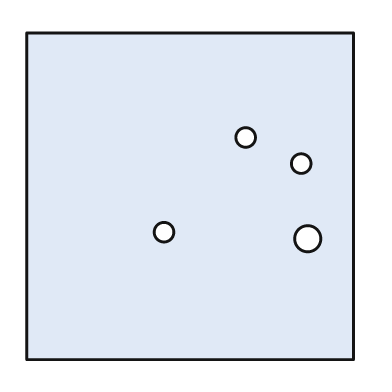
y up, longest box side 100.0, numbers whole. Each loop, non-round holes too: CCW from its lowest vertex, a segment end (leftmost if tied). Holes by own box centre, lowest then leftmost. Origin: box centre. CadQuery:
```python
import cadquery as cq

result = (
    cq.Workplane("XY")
    .moveTo(-50.0, -50.0)
    .lineTo(50.0, -50.0)
    .lineTo(50.0, 50.0)
    .lineTo(-50.0, 50.0)
    .close()
    .moveTo(36.0, -13.0)
    .circle(4.0)
    .moveTo(-8.0, -11.0)
    .circle(3.0)
    .moveTo(34.0, 10.0)
    .circle(3.0)
    .moveTo(17.0, 18.0)
    .circle(3.0)
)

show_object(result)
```